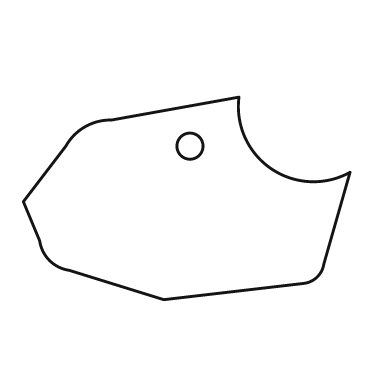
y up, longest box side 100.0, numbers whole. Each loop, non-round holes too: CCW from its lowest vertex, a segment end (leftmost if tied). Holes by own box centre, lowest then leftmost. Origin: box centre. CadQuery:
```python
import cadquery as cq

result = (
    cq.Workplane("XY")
    .moveTo(-7.0, -31.0)
    .lineTo(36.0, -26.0)
    .threePointArc((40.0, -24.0), (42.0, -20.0))
    .lineTo(50.0, 8.0)
    .threePointArc((26.0, 9.0), (16.0, 31.0))
    .lineTo(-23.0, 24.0)
    .threePointArc((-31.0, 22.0), (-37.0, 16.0))
    .lineTo(-50.0, -1.0)
    .lineTo(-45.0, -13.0)
    .threePointArc((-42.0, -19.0), (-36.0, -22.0))
    .close()
    .moveTo(1.0, 16.0)
    .circle(4.0)
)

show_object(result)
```